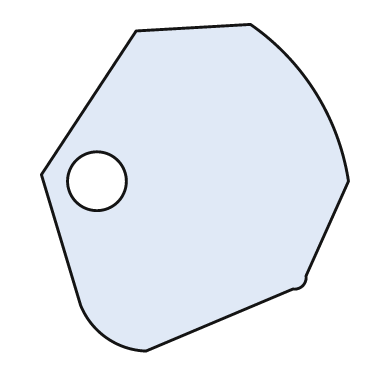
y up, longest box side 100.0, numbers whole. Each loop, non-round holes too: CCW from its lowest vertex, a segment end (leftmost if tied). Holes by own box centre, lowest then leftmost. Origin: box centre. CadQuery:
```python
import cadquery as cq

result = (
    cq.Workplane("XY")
    .moveTo(-15.0, -50.0)
    .lineTo(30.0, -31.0)
    .threePointArc((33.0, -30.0), (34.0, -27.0))
    .lineTo(47.0, 2.0)
    .threePointArc((37.0, 29.0), (17.0, 50.0))
    .lineTo(-18.0, 48.0)
    .lineTo(-47.0, 4.0)
    .lineTo(-35.0, -36.0)
    .threePointArc((-27.0, -46.0), (-15.0, -50.0))
    .close()
    .moveTo(-30.0, 2.0)
    .circle(9.0)
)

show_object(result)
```